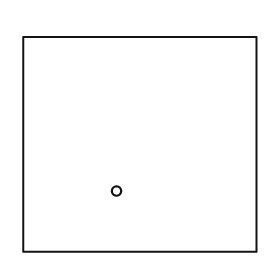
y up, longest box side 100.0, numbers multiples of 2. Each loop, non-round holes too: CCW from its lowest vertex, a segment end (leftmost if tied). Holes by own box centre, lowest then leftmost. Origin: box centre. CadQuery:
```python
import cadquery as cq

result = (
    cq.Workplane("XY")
    .moveTo(-50.0, -46.0)
    .lineTo(50.0, -46.0)
    .lineTo(50.0, 46.0)
    .lineTo(-50.0, 46.0)
    .close()
    .moveTo(-10.0, -20.0)
    .circle(2.0)
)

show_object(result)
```